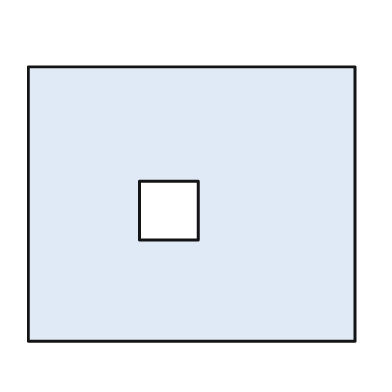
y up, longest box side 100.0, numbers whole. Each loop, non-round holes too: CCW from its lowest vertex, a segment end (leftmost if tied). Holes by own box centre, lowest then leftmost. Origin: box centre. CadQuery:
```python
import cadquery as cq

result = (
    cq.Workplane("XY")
    .moveTo(-50.0, -42.0)
    .lineTo(50.0, -42.0)
    .lineTo(50.0, 42.0)
    .lineTo(-50.0, 42.0)
    .close()
    .moveTo(-16.0, -11.0)
    .lineTo(2.0, -11.0)
    .lineTo(2.0, 7.0)
    .lineTo(-16.0, 7.0)
    .close()
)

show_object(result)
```